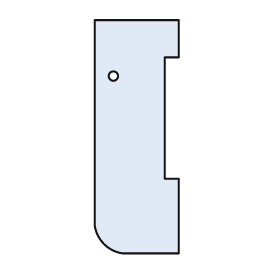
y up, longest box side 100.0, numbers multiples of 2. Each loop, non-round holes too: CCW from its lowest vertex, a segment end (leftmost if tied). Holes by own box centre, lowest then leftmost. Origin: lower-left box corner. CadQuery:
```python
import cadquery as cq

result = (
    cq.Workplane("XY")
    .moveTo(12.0, 0.0)
    .lineTo(36.0, 0.0)
    .lineTo(36.0, 32.0)
    .lineTo(30.0, 32.0)
    .lineTo(30.0, 84.0)
    .lineTo(36.0, 84.0)
    .lineTo(36.0, 100.0)
    .lineTo(0.0, 100.0)
    .lineTo(0.0, 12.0)
    .threePointArc((4.0, 4.0), (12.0, 0.0))
    .close()
    .moveTo(8.0, 76.0)
    .circle(2.0)
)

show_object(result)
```